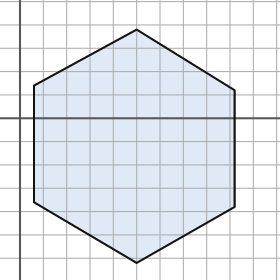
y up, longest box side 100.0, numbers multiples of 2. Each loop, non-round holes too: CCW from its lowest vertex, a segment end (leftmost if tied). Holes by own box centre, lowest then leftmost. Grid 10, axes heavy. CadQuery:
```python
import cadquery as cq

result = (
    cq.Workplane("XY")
    .moveTo(50.0, -62.0)
    .lineTo(92.0, -38.0)
    .lineTo(92.0, 12.0)
    .lineTo(50.0, 38.0)
    .lineTo(6.0, 14.0)
    .lineTo(6.0, -36.0)
    .close()
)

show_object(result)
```